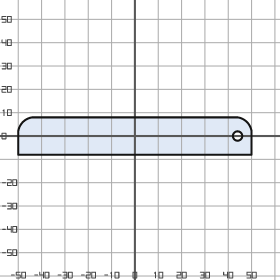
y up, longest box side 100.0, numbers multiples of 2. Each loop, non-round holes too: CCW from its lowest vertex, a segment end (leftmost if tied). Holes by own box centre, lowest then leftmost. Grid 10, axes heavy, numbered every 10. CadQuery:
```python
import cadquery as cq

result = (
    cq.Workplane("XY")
    .moveTo(-50.0, -8.0)
    .lineTo(50.0, -8.0)
    .lineTo(50.0, 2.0)
    .threePointArc((48.0, 6.0), (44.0, 8.0))
    .lineTo(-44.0, 8.0)
    .threePointArc((-48.0, 6.0), (-50.0, 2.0))
    .close()
    .moveTo(44.0, 0.0)
    .circle(2.0)
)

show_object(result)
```